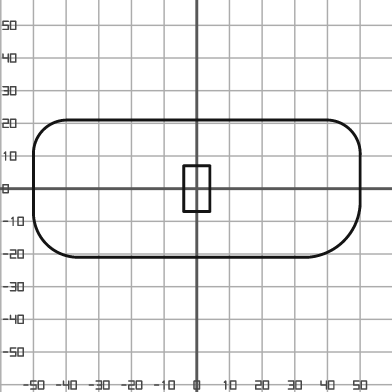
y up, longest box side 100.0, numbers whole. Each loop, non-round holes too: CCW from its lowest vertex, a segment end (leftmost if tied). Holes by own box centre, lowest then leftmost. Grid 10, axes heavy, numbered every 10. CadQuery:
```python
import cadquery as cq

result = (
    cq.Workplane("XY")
    .moveTo(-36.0, -21.0)
    .lineTo(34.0, -21.0)
    .threePointArc((45.0, -16.0), (50.0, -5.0))
    .lineTo(50.0, 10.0)
    .threePointArc((47.0, 18.0), (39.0, 21.0))
    .lineTo(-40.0, 21.0)
    .threePointArc((-47.0, 18.0), (-50.0, 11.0))
    .lineTo(-50.0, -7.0)
    .threePointArc((-46.0, -17.0), (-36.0, -21.0))
    .close()
    .moveTo(-4.0, -7.0)
    .lineTo(4.0, -7.0)
    .lineTo(4.0, 7.0)
    .lineTo(-4.0, 7.0)
    .close()
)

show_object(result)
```